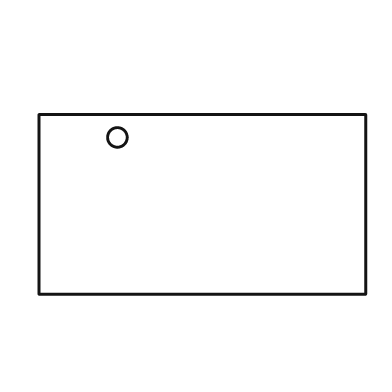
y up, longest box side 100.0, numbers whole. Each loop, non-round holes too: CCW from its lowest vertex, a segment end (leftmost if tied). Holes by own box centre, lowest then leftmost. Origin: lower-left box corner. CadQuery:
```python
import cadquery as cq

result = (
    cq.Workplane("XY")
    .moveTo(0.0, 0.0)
    .lineTo(100.0, 0.0)
    .lineTo(100.0, 55.0)
    .lineTo(0.0, 55.0)
    .close()
    .moveTo(24.0, 48.0)
    .circle(3.0)
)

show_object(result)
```